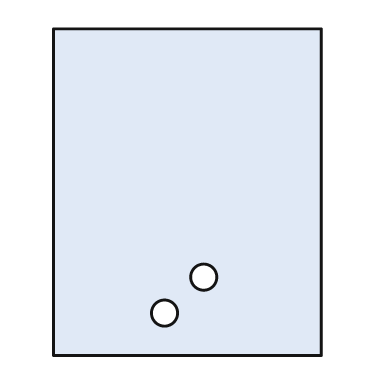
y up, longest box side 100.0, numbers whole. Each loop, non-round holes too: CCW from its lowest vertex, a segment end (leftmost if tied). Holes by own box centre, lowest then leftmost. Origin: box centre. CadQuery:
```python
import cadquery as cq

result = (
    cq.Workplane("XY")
    .moveTo(-41.0, -50.0)
    .lineTo(41.0, -50.0)
    .lineTo(41.0, 50.0)
    .lineTo(-41.0, 50.0)
    .close()
    .moveTo(-7.0, -37.0)
    .circle(4.0)
    .moveTo(5.0, -26.0)
    .circle(4.0)
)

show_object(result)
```